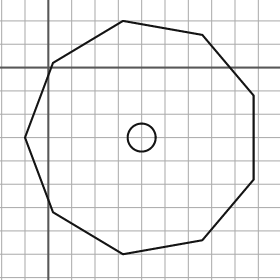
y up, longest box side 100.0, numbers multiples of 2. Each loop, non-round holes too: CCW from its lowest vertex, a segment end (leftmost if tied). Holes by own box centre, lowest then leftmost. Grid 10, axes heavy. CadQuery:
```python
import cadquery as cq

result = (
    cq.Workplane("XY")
    .moveTo(32.0, -80.0)
    .lineTo(66.0, -74.0)
    .lineTo(88.0, -48.0)
    .lineTo(88.0, -12.0)
    .lineTo(66.0, 14.0)
    .lineTo(32.0, 20.0)
    .lineTo(2.0, 2.0)
    .lineTo(-10.0, -30.0)
    .lineTo(2.0, -62.0)
    .close()
    .moveTo(40.0, -30.0)
    .circle(6.0)
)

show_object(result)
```